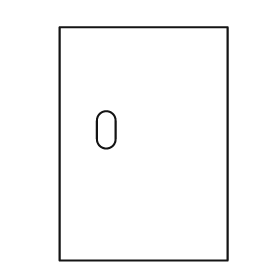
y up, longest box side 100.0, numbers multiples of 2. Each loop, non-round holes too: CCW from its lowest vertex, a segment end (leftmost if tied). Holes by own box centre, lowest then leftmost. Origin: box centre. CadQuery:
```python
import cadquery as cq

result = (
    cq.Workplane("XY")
    .moveTo(-36.0, -50.0)
    .lineTo(36.0, -50.0)
    .lineTo(36.0, 50.0)
    .lineTo(-36.0, 50.0)
    .close()
    .moveTo(-20.0, 2.0)
    .threePointArc((-16.0, -2.0), (-12.0, 2.0))
    .lineTo(-12.0, 10.0)
    .threePointArc((-16.0, 14.0), (-20.0, 10.0))
    .close()
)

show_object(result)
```